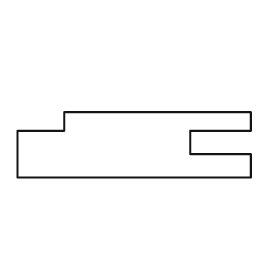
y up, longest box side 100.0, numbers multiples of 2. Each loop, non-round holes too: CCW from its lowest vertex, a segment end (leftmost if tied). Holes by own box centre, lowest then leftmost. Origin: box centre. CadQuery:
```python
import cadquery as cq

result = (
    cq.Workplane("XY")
    .moveTo(-50.0, -14.0)
    .lineTo(50.0, -14.0)
    .lineTo(50.0, -4.0)
    .lineTo(24.0, -4.0)
    .lineTo(24.0, 6.0)
    .lineTo(50.0, 6.0)
    .lineTo(50.0, 14.0)
    .lineTo(-30.0, 14.0)
    .lineTo(-30.0, 6.0)
    .lineTo(-50.0, 6.0)
    .close()
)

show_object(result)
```